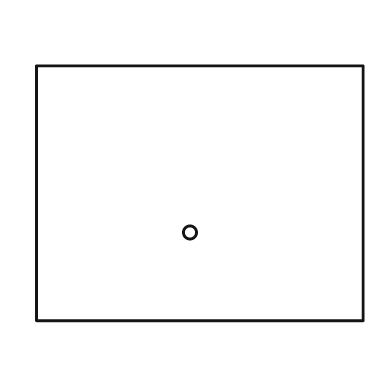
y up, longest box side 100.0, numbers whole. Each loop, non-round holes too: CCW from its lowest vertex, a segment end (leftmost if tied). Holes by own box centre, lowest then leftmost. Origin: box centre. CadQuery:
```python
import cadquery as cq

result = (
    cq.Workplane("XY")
    .moveTo(-50.0, -39.0)
    .lineTo(50.0, -39.0)
    .lineTo(50.0, 39.0)
    .lineTo(-50.0, 39.0)
    .close()
    .moveTo(-3.0, -12.0)
    .circle(2.0)
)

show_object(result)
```